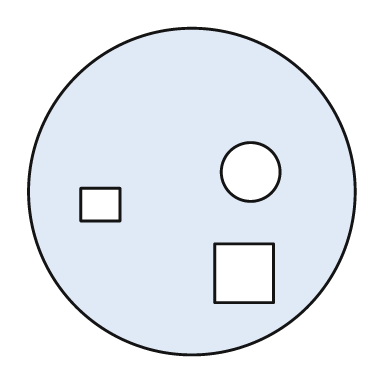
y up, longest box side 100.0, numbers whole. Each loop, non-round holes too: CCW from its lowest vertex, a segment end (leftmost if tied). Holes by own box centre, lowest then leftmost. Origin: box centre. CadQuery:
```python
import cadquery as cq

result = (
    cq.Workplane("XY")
    .moveTo(0.0, 0.0)
    .circle(50.0)
    .moveTo(7.0, -34.0)
    .lineTo(25.0, -34.0)
    .lineTo(25.0, -16.0)
    .lineTo(7.0, -16.0)
    .close()
    .moveTo(-34.0, -9.0)
    .lineTo(-22.0, -9.0)
    .lineTo(-22.0, 1.0)
    .lineTo(-34.0, 1.0)
    .close()
    .moveTo(18.0, 6.0)
    .circle(9.0)
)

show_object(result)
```